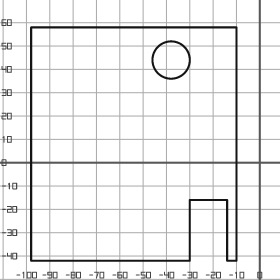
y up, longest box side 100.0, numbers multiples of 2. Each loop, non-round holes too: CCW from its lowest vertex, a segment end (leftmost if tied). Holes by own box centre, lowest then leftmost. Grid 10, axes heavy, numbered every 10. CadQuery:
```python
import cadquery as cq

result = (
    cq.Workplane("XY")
    .moveTo(-98.0, -42.0)
    .lineTo(-30.0, -42.0)
    .lineTo(-30.0, -16.0)
    .lineTo(-14.0, -16.0)
    .lineTo(-14.0, -42.0)
    .lineTo(-10.0, -42.0)
    .lineTo(-10.0, 58.0)
    .lineTo(-98.0, 58.0)
    .close()
    .moveTo(-38.0, 44.0)
    .circle(8.0)
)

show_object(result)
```